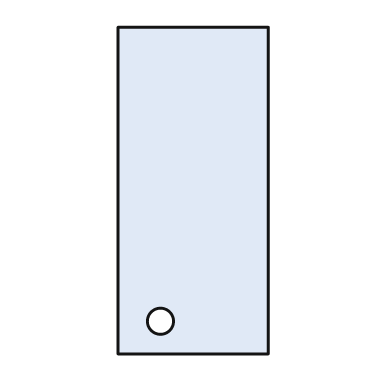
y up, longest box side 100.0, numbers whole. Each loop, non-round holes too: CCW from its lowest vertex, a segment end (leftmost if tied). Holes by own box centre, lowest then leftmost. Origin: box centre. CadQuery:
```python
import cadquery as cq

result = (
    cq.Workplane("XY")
    .moveTo(-23.0, -50.0)
    .lineTo(23.0, -50.0)
    .lineTo(23.0, 50.0)
    .lineTo(-23.0, 50.0)
    .close()
    .moveTo(-10.0, -40.0)
    .circle(4.0)
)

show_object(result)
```